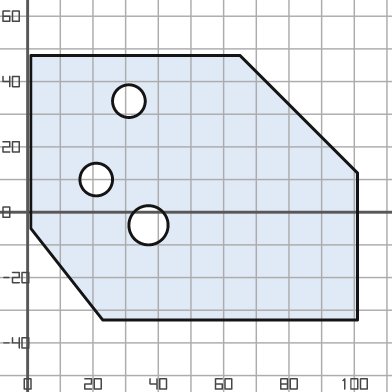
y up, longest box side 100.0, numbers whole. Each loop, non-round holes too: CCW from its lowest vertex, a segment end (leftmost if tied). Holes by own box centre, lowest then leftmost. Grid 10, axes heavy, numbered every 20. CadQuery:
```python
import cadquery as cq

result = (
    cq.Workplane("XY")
    .moveTo(23.0, -33.0)
    .lineTo(101.0, -33.0)
    .lineTo(101.0, 12.0)
    .lineTo(65.0, 48.0)
    .lineTo(1.0, 48.0)
    .lineTo(1.0, -5.0)
    .close()
    .moveTo(37.0, -4.0)
    .circle(6.0)
    .moveTo(21.0, 10.0)
    .circle(5.0)
    .moveTo(31.0, 34.0)
    .circle(5.0)
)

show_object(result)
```